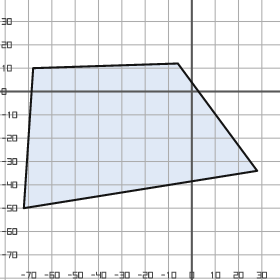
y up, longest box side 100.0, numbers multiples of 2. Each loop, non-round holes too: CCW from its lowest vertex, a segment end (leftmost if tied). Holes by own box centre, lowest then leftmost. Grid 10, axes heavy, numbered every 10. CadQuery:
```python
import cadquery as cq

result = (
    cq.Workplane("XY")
    .moveTo(-72.0, -50.0)
    .lineTo(28.0, -34.0)
    .lineTo(-6.0, 12.0)
    .lineTo(-68.0, 10.0)
    .close()
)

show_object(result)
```